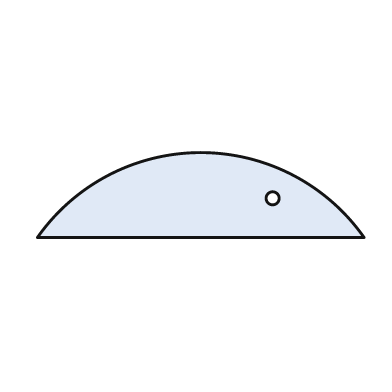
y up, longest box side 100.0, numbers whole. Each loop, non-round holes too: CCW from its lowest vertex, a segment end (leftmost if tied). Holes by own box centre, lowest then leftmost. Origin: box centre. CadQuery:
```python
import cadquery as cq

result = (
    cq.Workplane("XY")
    .moveTo(-50.0, -13.0)
    .lineTo(50.0, -13.0)
    .threePointArc((0.0, 13.0), (-50.0, -13.0))
    .close()
    .moveTo(22.0, -1.0)
    .circle(2.0)
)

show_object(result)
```